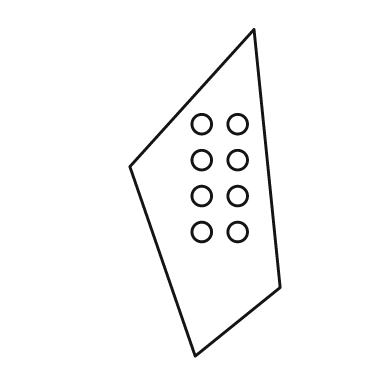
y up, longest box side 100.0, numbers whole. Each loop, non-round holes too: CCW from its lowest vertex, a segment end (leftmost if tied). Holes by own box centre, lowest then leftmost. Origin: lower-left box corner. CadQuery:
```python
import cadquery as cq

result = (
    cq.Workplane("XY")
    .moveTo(20.0, 0.0)
    .lineTo(46.0, 21.0)
    .lineTo(38.0, 100.0)
    .lineTo(0.0, 58.0)
    .close()
    .moveTo(22.0, 38.0)
    .circle(3.0)
    .moveTo(33.0, 38.0)
    .circle(3.0)
    .moveTo(22.0, 49.0)
    .circle(3.0)
    .moveTo(33.0, 49.0)
    .circle(3.0)
    .moveTo(22.0, 60.0)
    .circle(3.0)
    .moveTo(33.0, 60.0)
    .circle(3.0)
    .moveTo(22.0, 71.0)
    .circle(3.0)
    .moveTo(33.0, 71.0)
    .circle(3.0)
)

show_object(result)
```